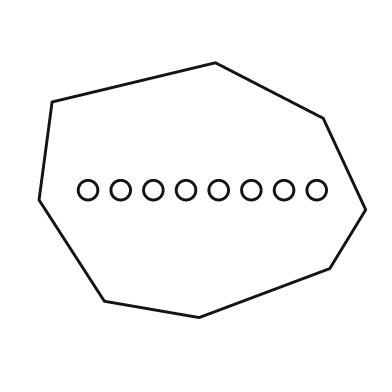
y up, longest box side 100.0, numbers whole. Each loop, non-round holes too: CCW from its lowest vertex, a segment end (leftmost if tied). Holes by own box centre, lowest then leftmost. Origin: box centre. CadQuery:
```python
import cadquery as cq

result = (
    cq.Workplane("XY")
    .moveTo(-1.0, -39.0)
    .lineTo(39.0, -24.0)
    .lineTo(50.0, -6.0)
    .lineTo(37.0, 22.0)
    .lineTo(4.0, 39.0)
    .lineTo(-46.0, 27.0)
    .lineTo(-50.0, -3.0)
    .lineTo(-30.0, -34.0)
    .close()
    .moveTo(-35.0, 0.0)
    .circle(3.0)
    .moveTo(-25.0, 0.0)
    .circle(3.0)
    .moveTo(-15.0, 0.0)
    .circle(3.0)
    .moveTo(-5.0, 0.0)
    .circle(3.0)
    .moveTo(5.0, 0.0)
    .circle(3.0)
    .moveTo(15.0, 0.0)
    .circle(3.0)
    .moveTo(25.0, 0.0)
    .circle(3.0)
    .moveTo(35.0, 0.0)
    .circle(3.0)
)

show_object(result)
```